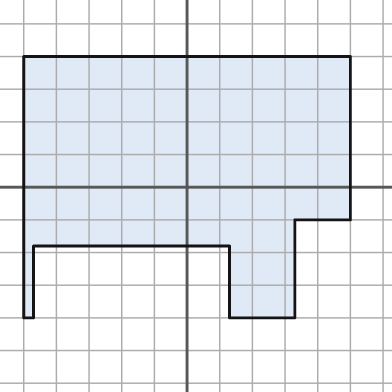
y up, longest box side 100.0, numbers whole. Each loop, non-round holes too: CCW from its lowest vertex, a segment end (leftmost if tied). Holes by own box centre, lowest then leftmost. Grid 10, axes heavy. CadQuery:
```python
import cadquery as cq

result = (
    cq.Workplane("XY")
    .moveTo(-50.0, -40.0)
    .lineTo(-47.0, -40.0)
    .lineTo(-47.0, -18.0)
    .lineTo(13.0, -18.0)
    .lineTo(13.0, -40.0)
    .lineTo(33.0, -40.0)
    .lineTo(33.0, -10.0)
    .lineTo(50.0, -10.0)
    .lineTo(50.0, 40.0)
    .lineTo(-50.0, 40.0)
    .close()
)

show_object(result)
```